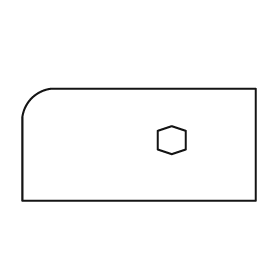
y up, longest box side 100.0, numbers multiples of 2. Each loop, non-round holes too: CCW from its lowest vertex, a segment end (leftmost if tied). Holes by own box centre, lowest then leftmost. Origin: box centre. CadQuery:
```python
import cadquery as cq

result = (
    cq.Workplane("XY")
    .moveTo(-50.0, -24.0)
    .lineTo(50.0, -24.0)
    .lineTo(50.0, 24.0)
    .lineTo(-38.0, 24.0)
    .threePointArc((-46.0, 20.0), (-50.0, 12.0))
    .close()
    .moveTo(14.0, -4.0)
    .lineTo(20.0, -2.0)
    .lineTo(20.0, 6.0)
    .lineTo(14.0, 8.0)
    .lineTo(8.0, 6.0)
    .lineTo(8.0, -2.0)
    .close()
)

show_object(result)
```